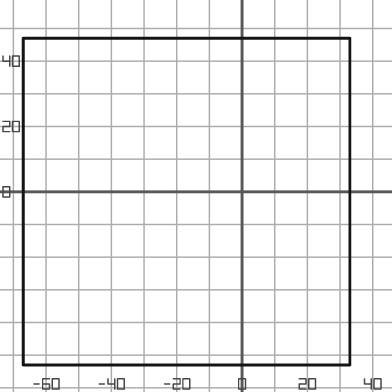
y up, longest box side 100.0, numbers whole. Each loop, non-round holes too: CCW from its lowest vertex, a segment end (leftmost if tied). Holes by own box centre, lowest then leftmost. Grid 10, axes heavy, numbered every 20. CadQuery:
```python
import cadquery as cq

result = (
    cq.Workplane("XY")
    .moveTo(-67.0, -53.0)
    .lineTo(33.0, -53.0)
    .lineTo(33.0, 47.0)
    .lineTo(-67.0, 47.0)
    .close()
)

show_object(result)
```